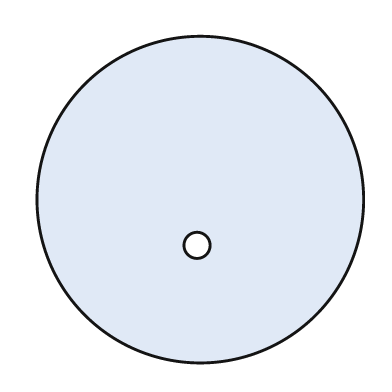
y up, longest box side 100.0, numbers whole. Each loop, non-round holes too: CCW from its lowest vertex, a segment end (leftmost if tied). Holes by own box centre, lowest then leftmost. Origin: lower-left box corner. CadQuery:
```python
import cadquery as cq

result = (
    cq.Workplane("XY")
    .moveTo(50.0, 50.0)
    .circle(50.0)
    .moveTo(49.0, 36.0)
    .circle(4.0)
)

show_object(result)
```